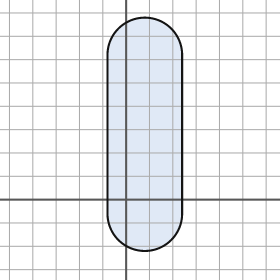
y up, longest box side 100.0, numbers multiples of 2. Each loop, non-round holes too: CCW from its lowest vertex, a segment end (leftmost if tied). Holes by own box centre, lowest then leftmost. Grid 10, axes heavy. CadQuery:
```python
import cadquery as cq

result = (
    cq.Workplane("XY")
    .moveTo(-8.0, -6.0)
    .threePointArc((8.0, -22.0), (24.0, -6.0))
    .lineTo(24.0, 62.0)
    .threePointArc((8.0, 78.0), (-8.0, 62.0))
    .close()
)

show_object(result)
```